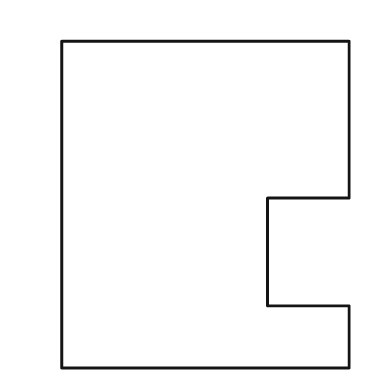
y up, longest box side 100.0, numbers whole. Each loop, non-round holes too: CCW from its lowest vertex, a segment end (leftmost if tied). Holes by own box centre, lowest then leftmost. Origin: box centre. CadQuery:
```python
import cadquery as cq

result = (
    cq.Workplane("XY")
    .moveTo(-44.0, -50.0)
    .lineTo(44.0, -50.0)
    .lineTo(44.0, -31.0)
    .lineTo(19.0, -31.0)
    .lineTo(19.0, 2.0)
    .lineTo(44.0, 2.0)
    .lineTo(44.0, 50.0)
    .lineTo(-44.0, 50.0)
    .close()
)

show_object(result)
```